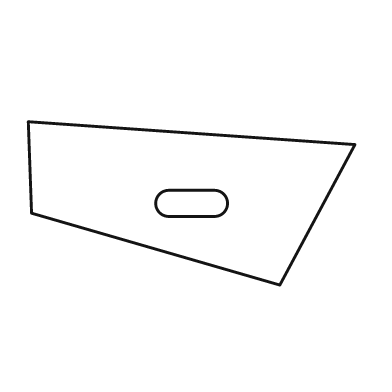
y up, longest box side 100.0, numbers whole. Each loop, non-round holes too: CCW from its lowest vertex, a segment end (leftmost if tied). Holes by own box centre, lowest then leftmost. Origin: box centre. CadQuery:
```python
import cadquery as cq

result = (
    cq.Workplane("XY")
    .moveTo(27.0, -25.0)
    .lineTo(50.0, 18.0)
    .lineTo(-50.0, 25.0)
    .lineTo(-49.0, -3.0)
    .close()
    .moveTo(-7.0, -4.0)
    .lineTo(7.0, -4.0)
    .threePointArc((11.0, 0.0), (7.0, 4.0))
    .lineTo(-7.0, 4.0)
    .threePointArc((-11.0, 0.0), (-7.0, -4.0))
    .close()
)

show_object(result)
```